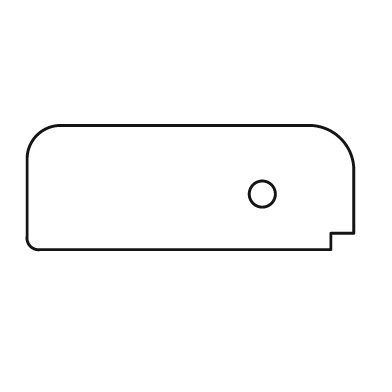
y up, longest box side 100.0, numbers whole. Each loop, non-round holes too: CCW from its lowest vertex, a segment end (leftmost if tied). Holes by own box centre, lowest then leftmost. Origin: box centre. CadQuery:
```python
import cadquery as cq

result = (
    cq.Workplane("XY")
    .moveTo(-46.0, -19.0)
    .lineTo(43.0, -19.0)
    .lineTo(43.0, -14.0)
    .lineTo(50.0, -14.0)
    .lineTo(50.0, 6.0)
    .threePointArc((46.0, 15.0), (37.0, 19.0))
    .lineTo(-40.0, 19.0)
    .threePointArc((-47.0, 16.0), (-50.0, 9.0))
    .lineTo(-50.0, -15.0)
    .threePointArc((-49.0, -18.0), (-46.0, -19.0))
    .close()
    .moveTo(22.0, -2.0)
    .circle(4.0)
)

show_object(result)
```